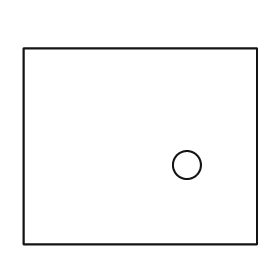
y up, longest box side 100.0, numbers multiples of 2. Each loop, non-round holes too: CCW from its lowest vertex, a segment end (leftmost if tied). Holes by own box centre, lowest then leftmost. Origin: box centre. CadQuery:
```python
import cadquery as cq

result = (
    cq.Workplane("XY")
    .moveTo(-50.0, -42.0)
    .lineTo(50.0, -42.0)
    .lineTo(50.0, 42.0)
    .lineTo(-50.0, 42.0)
    .close()
    .moveTo(20.0, -8.0)
    .circle(6.0)
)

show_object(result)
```